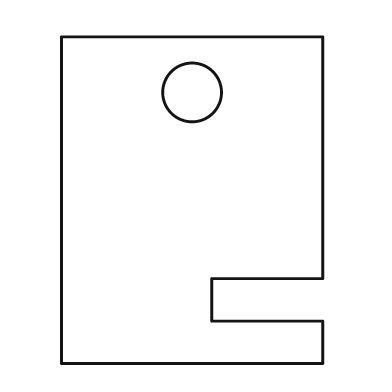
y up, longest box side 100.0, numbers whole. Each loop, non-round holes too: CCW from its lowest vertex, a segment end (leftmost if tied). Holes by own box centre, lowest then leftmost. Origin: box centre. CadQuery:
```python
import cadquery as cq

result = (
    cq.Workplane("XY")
    .moveTo(-40.0, -50.0)
    .lineTo(40.0, -50.0)
    .lineTo(40.0, -37.0)
    .lineTo(6.0, -37.0)
    .lineTo(6.0, -24.0)
    .lineTo(40.0, -24.0)
    .lineTo(40.0, 50.0)
    .lineTo(-40.0, 50.0)
    .close()
    .moveTo(0.0, 33.0)
    .circle(9.0)
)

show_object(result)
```